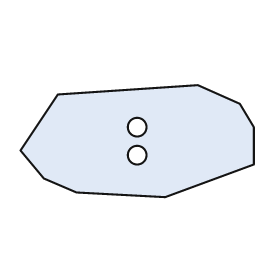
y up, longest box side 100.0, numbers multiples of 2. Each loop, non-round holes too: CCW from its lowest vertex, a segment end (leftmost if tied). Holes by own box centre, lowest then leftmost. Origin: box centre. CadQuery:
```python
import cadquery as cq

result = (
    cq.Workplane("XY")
    .moveTo(12.0, -24.0)
    .lineTo(50.0, -10.0)
    .lineTo(50.0, 6.0)
    .lineTo(44.0, 16.0)
    .lineTo(26.0, 24.0)
    .lineTo(-34.0, 20.0)
    .lineTo(-50.0, -4.0)
    .lineTo(-40.0, -16.0)
    .lineTo(-26.0, -22.0)
    .close()
    .moveTo(0.0, -6.0)
    .circle(4.0)
    .moveTo(0.0, 6.0)
    .circle(4.0)
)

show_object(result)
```